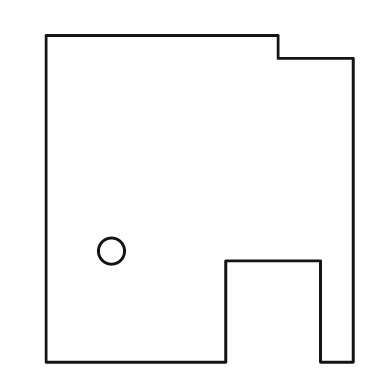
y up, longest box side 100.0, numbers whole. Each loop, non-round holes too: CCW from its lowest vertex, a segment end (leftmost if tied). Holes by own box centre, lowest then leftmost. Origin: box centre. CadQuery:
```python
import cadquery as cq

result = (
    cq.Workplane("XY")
    .moveTo(-47.0, -50.0)
    .lineTo(8.0, -50.0)
    .lineTo(8.0, -19.0)
    .lineTo(37.0, -19.0)
    .lineTo(37.0, -50.0)
    .lineTo(47.0, -50.0)
    .lineTo(47.0, 43.0)
    .lineTo(24.0, 43.0)
    .lineTo(24.0, 50.0)
    .lineTo(-47.0, 50.0)
    .close()
    .moveTo(-27.0, -16.0)
    .circle(4.0)
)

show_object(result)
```